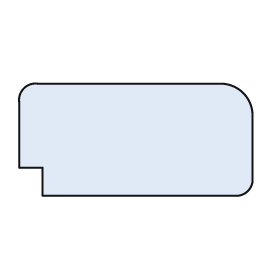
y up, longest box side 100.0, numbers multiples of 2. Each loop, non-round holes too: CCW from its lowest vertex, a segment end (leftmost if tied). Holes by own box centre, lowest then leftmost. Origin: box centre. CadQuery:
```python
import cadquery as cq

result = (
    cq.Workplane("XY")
    .moveTo(-40.0, -24.0)
    .lineTo(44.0, -24.0)
    .threePointArc((48.0, -22.0), (50.0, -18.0))
    .lineTo(50.0, 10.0)
    .threePointArc((46.0, 20.0), (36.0, 24.0))
    .lineTo(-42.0, 24.0)
    .threePointArc((-48.0, 22.0), (-50.0, 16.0))
    .lineTo(-50.0, -12.0)
    .lineTo(-40.0, -12.0)
    .close()
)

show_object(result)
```